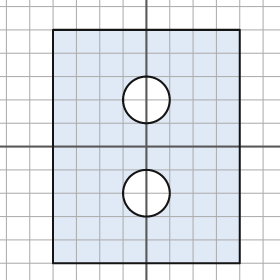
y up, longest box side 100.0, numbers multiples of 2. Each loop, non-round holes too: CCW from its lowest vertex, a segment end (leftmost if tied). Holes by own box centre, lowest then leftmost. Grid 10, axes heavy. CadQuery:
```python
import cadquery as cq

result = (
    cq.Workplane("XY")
    .moveTo(-40.0, -50.0)
    .lineTo(40.0, -50.0)
    .lineTo(40.0, 50.0)
    .lineTo(-40.0, 50.0)
    .close()
    .moveTo(0.0, -20.0)
    .circle(10.0)
    .moveTo(0.0, 20.0)
    .circle(10.0)
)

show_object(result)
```